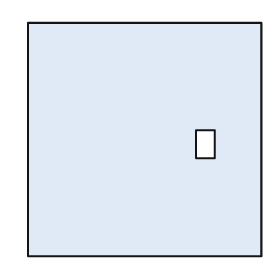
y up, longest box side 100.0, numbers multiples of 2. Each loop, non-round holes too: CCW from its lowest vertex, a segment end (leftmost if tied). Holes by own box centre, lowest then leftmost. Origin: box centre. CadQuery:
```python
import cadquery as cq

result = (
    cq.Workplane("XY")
    .moveTo(-50.0, -50.0)
    .lineTo(50.0, -50.0)
    .lineTo(50.0, 50.0)
    .lineTo(-50.0, 50.0)
    .close()
    .moveTo(22.0, -8.0)
    .lineTo(30.0, -8.0)
    .lineTo(30.0, 4.0)
    .lineTo(22.0, 4.0)
    .close()
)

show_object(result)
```